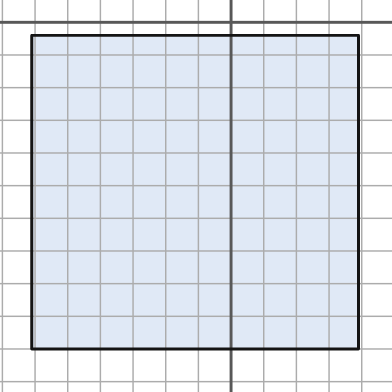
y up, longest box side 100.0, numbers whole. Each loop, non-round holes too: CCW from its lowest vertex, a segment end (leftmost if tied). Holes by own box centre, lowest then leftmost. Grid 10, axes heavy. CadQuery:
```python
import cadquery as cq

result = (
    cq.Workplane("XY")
    .moveTo(-61.0, -100.0)
    .lineTo(39.0, -100.0)
    .lineTo(39.0, -4.0)
    .lineTo(-61.0, -4.0)
    .close()
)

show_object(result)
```